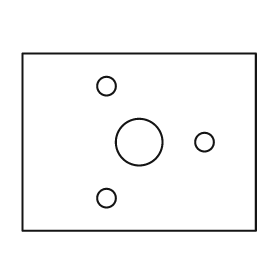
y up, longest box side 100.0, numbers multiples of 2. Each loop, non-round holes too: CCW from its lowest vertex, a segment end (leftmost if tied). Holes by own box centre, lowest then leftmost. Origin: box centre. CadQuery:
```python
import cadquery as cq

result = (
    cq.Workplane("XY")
    .moveTo(-50.0, -38.0)
    .lineTo(50.0, -38.0)
    .lineTo(50.0, 38.0)
    .lineTo(-50.0, 38.0)
    .close()
    .moveTo(-14.0, -24.0)
    .circle(4.0)
    .moveTo(0.0, 0.0)
    .circle(10.0)
    .moveTo(28.0, 0.0)
    .circle(4.0)
    .moveTo(-14.0, 24.0)
    .circle(4.0)
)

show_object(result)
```